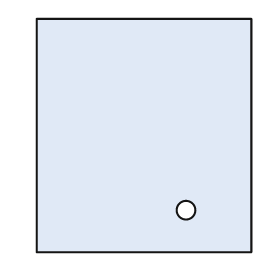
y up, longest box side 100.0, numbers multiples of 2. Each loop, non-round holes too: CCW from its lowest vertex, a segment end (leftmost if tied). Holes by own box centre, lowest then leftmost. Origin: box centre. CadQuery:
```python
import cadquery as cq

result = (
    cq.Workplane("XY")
    .moveTo(-46.0, -50.0)
    .lineTo(46.0, -50.0)
    .lineTo(46.0, 50.0)
    .lineTo(-46.0, 50.0)
    .close()
    .moveTo(18.0, -32.0)
    .circle(4.0)
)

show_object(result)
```